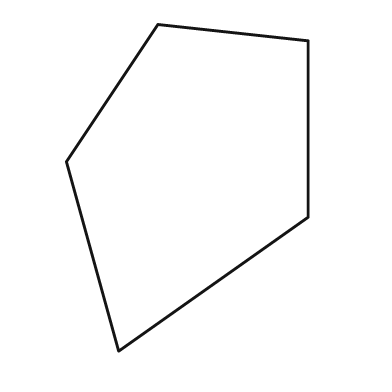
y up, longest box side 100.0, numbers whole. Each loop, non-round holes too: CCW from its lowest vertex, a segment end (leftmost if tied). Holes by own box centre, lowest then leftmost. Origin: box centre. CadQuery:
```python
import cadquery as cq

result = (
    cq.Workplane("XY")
    .moveTo(-21.0, -50.0)
    .lineTo(37.0, -9.0)
    .lineTo(37.0, 45.0)
    .lineTo(-9.0, 50.0)
    .lineTo(-37.0, 8.0)
    .close()
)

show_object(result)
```